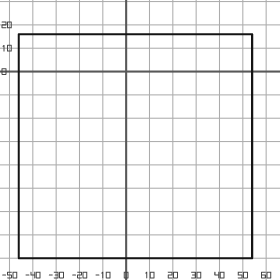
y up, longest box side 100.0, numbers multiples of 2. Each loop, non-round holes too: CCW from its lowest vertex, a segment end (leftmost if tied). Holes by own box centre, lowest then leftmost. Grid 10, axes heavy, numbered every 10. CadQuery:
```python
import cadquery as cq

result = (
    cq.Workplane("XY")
    .moveTo(-46.0, -80.0)
    .lineTo(54.0, -80.0)
    .lineTo(54.0, 16.0)
    .lineTo(-46.0, 16.0)
    .close()
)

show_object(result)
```